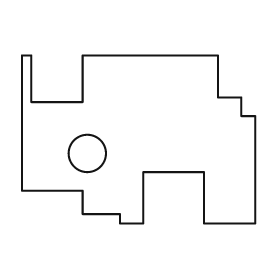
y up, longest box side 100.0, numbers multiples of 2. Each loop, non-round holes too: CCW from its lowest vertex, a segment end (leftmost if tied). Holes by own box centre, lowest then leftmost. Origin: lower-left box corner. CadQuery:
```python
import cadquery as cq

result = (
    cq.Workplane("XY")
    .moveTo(42.0, 0.0)
    .lineTo(52.0, 0.0)
    .lineTo(52.0, 22.0)
    .lineTo(78.0, 22.0)
    .lineTo(78.0, 0.0)
    .lineTo(100.0, 0.0)
    .lineTo(100.0, 46.0)
    .lineTo(94.0, 46.0)
    .lineTo(94.0, 54.0)
    .lineTo(84.0, 54.0)
    .lineTo(84.0, 72.0)
    .lineTo(26.0, 72.0)
    .lineTo(26.0, 52.0)
    .lineTo(4.0, 52.0)
    .lineTo(4.0, 72.0)
    .lineTo(0.0, 72.0)
    .lineTo(0.0, 14.0)
    .lineTo(26.0, 14.0)
    .lineTo(26.0, 4.0)
    .lineTo(42.0, 4.0)
    .close()
    .moveTo(28.0, 30.0)
    .circle(8.0)
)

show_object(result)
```